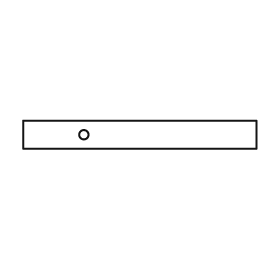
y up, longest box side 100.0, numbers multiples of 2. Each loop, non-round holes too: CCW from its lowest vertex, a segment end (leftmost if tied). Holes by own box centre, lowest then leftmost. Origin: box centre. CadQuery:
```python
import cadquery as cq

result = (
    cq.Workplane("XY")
    .moveTo(-50.0, -6.0)
    .lineTo(50.0, -6.0)
    .lineTo(50.0, 6.0)
    .lineTo(-50.0, 6.0)
    .close()
    .moveTo(-24.0, 0.0)
    .circle(2.0)
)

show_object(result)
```